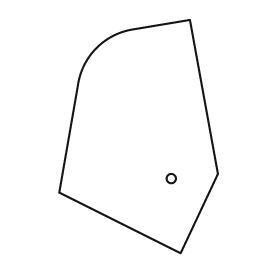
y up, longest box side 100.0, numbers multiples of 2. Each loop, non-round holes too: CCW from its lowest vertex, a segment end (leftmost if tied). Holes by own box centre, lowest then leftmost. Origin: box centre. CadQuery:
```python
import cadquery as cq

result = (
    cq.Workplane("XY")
    .moveTo(18.0, -50.0)
    .lineTo(34.0, -16.0)
    .lineTo(22.0, 50.0)
    .lineTo(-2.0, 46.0)
    .threePointArc((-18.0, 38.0), (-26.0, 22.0))
    .lineTo(-34.0, -24.0)
    .close()
    .moveTo(14.0, -18.0)
    .circle(2.0)
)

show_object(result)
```